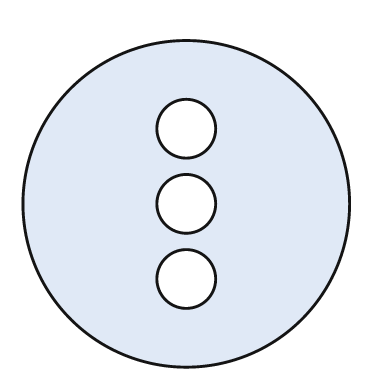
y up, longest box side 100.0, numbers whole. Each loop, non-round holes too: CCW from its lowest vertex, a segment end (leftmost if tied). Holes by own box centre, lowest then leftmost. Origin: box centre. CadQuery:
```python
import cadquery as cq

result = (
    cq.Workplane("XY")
    .moveTo(0.0, 0.0)
    .circle(50.0)
    .moveTo(0.0, -23.0)
    .circle(9.0)
    .moveTo(0.0, 0.0)
    .circle(9.0)
    .moveTo(0.0, 23.0)
    .circle(9.0)
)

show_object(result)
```